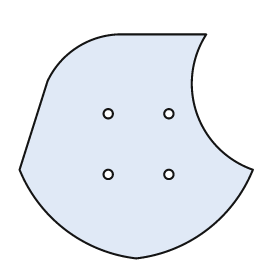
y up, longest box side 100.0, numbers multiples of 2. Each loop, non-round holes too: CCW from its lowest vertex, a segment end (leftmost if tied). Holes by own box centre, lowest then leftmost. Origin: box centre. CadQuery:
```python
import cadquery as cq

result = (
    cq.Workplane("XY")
    .moveTo(0.0, -48.0)
    .threePointArc((30.0, -36.0), (50.0, -10.0))
    .threePointArc((26.0, 14.0), (30.0, 48.0))
    .lineTo(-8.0, 48.0)
    .threePointArc((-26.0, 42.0), (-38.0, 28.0))
    .lineTo(-50.0, -10.0)
    .threePointArc((-30.0, -36.0), (0.0, -48.0))
    .close()
    .moveTo(-12.0, -12.0)
    .circle(2.0)
    .moveTo(14.0, -12.0)
    .circle(2.0)
    .moveTo(-12.0, 14.0)
    .circle(2.0)
    .moveTo(14.0, 14.0)
    .circle(2.0)
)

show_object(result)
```